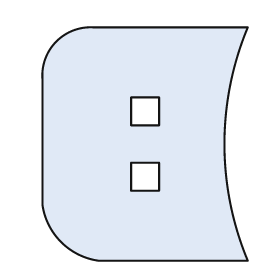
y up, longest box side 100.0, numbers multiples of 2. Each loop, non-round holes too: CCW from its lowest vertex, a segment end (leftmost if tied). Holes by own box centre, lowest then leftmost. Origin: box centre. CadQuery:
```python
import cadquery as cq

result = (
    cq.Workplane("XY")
    .moveTo(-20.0, -50.0)
    .lineTo(44.0, -50.0)
    .threePointArc((34.0, 0.0), (44.0, 50.0))
    .lineTo(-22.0, 50.0)
    .threePointArc((-38.0, 44.0), (-44.0, 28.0))
    .lineTo(-44.0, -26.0)
    .threePointArc((-36.0, -42.0), (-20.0, -50.0))
    .close()
    .moveTo(-6.0, -20.0)
    .lineTo(6.0, -20.0)
    .lineTo(6.0, -8.0)
    .lineTo(-6.0, -8.0)
    .close()
    .moveTo(-6.0, 8.0)
    .lineTo(6.0, 8.0)
    .lineTo(6.0, 20.0)
    .lineTo(-6.0, 20.0)
    .close()
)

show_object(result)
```